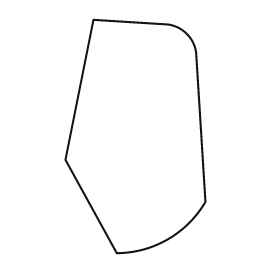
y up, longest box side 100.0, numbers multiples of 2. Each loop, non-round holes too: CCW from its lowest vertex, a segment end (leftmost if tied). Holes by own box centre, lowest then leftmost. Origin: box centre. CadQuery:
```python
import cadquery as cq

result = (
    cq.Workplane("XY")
    .moveTo(-8.0, -50.0)
    .threePointArc((14.0, -44.0), (30.0, -28.0))
    .lineTo(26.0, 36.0)
    .threePointArc((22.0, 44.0), (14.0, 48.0))
    .lineTo(-18.0, 50.0)
    .lineTo(-30.0, -10.0)
    .close()
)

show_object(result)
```